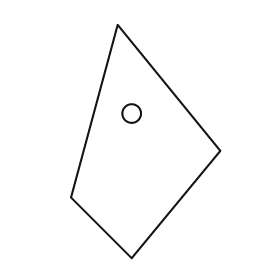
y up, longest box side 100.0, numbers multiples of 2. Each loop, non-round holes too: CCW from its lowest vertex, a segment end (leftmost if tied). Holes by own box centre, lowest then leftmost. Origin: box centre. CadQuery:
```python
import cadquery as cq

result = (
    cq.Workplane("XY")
    .moveTo(-6.0, -50.0)
    .lineTo(32.0, -4.0)
    .lineTo(-12.0, 50.0)
    .lineTo(-32.0, -24.0)
    .close()
    .moveTo(-6.0, 12.0)
    .circle(4.0)
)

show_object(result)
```